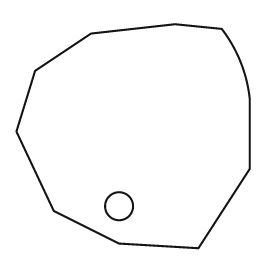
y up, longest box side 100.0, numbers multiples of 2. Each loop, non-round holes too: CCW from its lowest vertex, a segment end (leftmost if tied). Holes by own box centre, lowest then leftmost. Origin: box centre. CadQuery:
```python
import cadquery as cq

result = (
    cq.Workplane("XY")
    .moveTo(28.0, -48.0)
    .lineTo(50.0, -14.0)
    .lineTo(50.0, 16.0)
    .threePointArc((46.0, 32.0), (38.0, 46.0))
    .lineTo(18.0, 48.0)
    .lineTo(-18.0, 44.0)
    .lineTo(-42.0, 28.0)
    .lineTo(-50.0, 2.0)
    .lineTo(-34.0, -32.0)
    .lineTo(-6.0, -46.0)
    .close()
    .moveTo(-6.0, -30.0)
    .circle(6.0)
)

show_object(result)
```